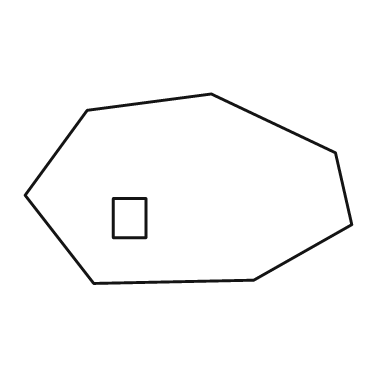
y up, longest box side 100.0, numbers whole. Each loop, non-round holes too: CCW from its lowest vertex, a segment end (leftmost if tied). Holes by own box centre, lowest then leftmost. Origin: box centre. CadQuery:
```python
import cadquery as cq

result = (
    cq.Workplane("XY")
    .moveTo(-29.0, -29.0)
    .lineTo(20.0, -28.0)
    .lineTo(50.0, -11.0)
    .lineTo(45.0, 11.0)
    .lineTo(7.0, 29.0)
    .lineTo(-31.0, 24.0)
    .lineTo(-50.0, -2.0)
    .close()
    .moveTo(-23.0, -15.0)
    .lineTo(-13.0, -15.0)
    .lineTo(-13.0, -3.0)
    .lineTo(-23.0, -3.0)
    .close()
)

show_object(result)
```